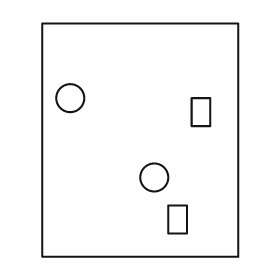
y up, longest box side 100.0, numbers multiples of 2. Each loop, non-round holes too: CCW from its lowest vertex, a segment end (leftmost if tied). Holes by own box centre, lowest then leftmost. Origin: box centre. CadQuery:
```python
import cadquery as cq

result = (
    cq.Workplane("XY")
    .moveTo(-42.0, -50.0)
    .lineTo(42.0, -50.0)
    .lineTo(42.0, 50.0)
    .lineTo(-42.0, 50.0)
    .close()
    .moveTo(12.0, -40.0)
    .lineTo(20.0, -40.0)
    .lineTo(20.0, -28.0)
    .lineTo(12.0, -28.0)
    .close()
    .moveTo(6.0, -16.0)
    .circle(6.0)
    .moveTo(22.0, 6.0)
    .lineTo(30.0, 6.0)
    .lineTo(30.0, 18.0)
    .lineTo(22.0, 18.0)
    .close()
    .moveTo(-30.0, 18.0)
    .circle(6.0)
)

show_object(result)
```